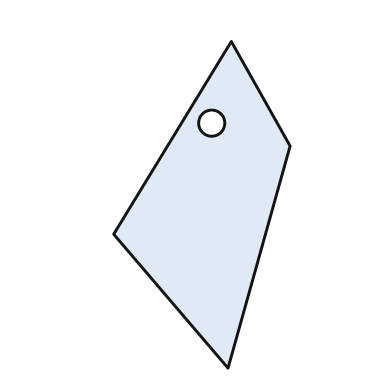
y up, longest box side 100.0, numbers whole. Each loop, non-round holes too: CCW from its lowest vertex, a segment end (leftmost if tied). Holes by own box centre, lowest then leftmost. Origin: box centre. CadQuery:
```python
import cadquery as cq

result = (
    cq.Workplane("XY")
    .moveTo(8.0, -50.0)
    .lineTo(27.0, 18.0)
    .lineTo(9.0, 50.0)
    .lineTo(-27.0, -9.0)
    .close()
    .moveTo(3.0, 25.0)
    .circle(4.0)
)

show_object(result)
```